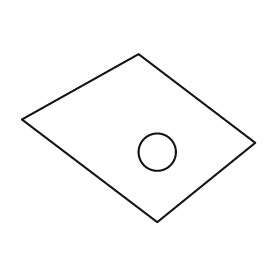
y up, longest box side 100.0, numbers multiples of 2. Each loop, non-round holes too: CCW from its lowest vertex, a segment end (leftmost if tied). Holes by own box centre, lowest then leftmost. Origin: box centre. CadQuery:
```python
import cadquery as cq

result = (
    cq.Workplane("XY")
    .moveTo(8.0, -36.0)
    .lineTo(50.0, -2.0)
    .lineTo(0.0, 36.0)
    .lineTo(-50.0, 8.0)
    .close()
    .moveTo(8.0, -6.0)
    .circle(8.0)
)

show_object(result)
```